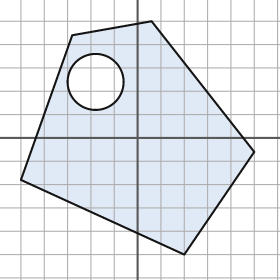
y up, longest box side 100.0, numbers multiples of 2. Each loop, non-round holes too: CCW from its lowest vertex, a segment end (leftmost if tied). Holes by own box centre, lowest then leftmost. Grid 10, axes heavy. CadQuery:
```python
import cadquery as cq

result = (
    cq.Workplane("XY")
    .moveTo(20.0, -50.0)
    .lineTo(50.0, -6.0)
    .lineTo(6.0, 50.0)
    .lineTo(-28.0, 44.0)
    .lineTo(-50.0, -18.0)
    .close()
    .moveTo(-18.0, 24.0)
    .circle(12.0)
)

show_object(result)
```